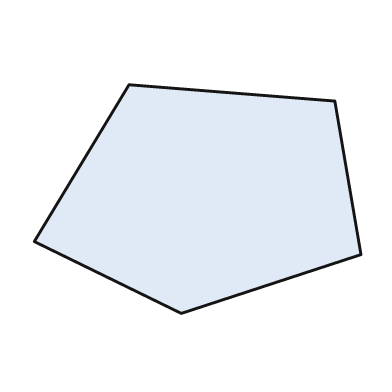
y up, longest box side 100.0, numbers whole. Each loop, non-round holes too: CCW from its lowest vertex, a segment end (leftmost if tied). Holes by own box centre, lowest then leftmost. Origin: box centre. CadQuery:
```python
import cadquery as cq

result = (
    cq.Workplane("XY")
    .moveTo(-5.0, -35.0)
    .lineTo(50.0, -17.0)
    .lineTo(42.0, 30.0)
    .lineTo(-21.0, 35.0)
    .lineTo(-50.0, -13.0)
    .close()
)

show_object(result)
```